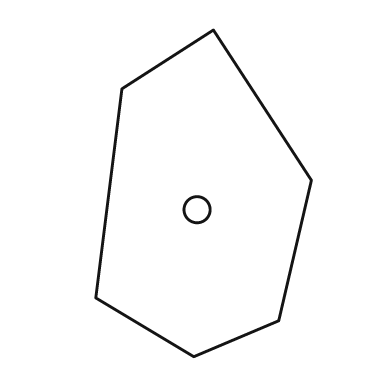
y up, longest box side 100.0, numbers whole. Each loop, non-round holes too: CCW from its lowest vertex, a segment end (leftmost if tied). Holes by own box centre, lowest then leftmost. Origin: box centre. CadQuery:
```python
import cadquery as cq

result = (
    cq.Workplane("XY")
    .moveTo(-3.0, -50.0)
    .lineTo(23.0, -39.0)
    .lineTo(33.0, 4.0)
    .lineTo(3.0, 50.0)
    .lineTo(-25.0, 32.0)
    .lineTo(-33.0, -32.0)
    .close()
    .moveTo(-2.0, -5.0)
    .circle(4.0)
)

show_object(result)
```